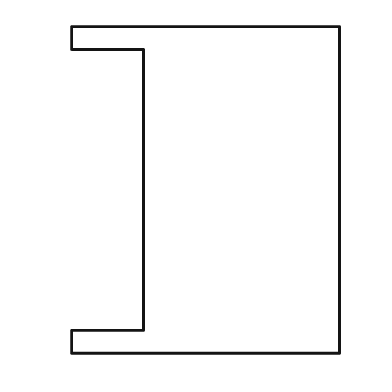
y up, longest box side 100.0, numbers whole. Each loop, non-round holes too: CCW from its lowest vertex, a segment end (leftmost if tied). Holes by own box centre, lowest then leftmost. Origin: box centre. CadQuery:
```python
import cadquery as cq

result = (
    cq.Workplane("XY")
    .moveTo(-41.0, -50.0)
    .lineTo(41.0, -50.0)
    .lineTo(41.0, 50.0)
    .lineTo(-41.0, 50.0)
    .lineTo(-41.0, 43.0)
    .lineTo(-19.0, 43.0)
    .lineTo(-19.0, -43.0)
    .lineTo(-41.0, -43.0)
    .close()
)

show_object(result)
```